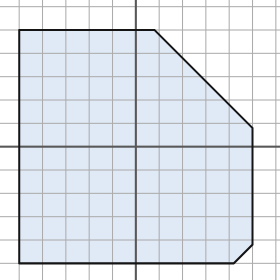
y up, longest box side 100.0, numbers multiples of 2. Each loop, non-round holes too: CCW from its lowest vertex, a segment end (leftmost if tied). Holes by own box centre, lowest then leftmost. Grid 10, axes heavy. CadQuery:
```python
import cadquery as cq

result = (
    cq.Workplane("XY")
    .moveTo(-50.0, -50.0)
    .lineTo(42.0, -50.0)
    .lineTo(50.0, -42.0)
    .lineTo(50.0, 8.0)
    .lineTo(8.0, 50.0)
    .lineTo(-50.0, 50.0)
    .close()
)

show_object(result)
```